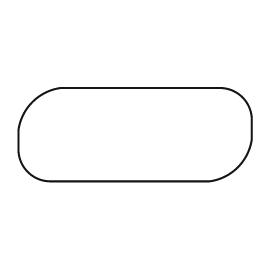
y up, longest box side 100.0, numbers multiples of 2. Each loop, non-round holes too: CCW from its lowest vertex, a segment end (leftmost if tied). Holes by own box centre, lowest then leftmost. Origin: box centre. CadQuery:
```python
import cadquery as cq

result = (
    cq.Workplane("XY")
    .moveTo(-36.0, -20.0)
    .lineTo(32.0, -20.0)
    .threePointArc((44.0, -14.0), (50.0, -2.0))
    .lineTo(50.0, 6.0)
    .threePointArc((46.0, 16.0), (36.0, 20.0))
    .lineTo(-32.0, 20.0)
    .threePointArc((-44.0, 14.0), (-50.0, 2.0))
    .lineTo(-50.0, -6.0)
    .threePointArc((-46.0, -16.0), (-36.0, -20.0))
    .close()
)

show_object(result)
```